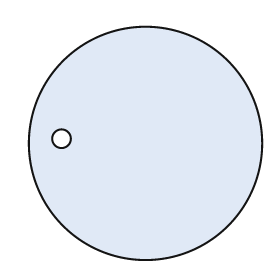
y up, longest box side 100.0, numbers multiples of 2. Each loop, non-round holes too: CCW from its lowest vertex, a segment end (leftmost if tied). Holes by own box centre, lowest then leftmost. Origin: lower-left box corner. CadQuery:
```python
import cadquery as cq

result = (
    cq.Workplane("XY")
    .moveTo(50.0, 50.0)
    .circle(50.0)
    .moveTo(14.0, 52.0)
    .circle(4.0)
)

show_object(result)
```